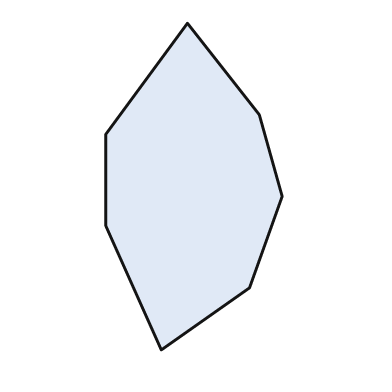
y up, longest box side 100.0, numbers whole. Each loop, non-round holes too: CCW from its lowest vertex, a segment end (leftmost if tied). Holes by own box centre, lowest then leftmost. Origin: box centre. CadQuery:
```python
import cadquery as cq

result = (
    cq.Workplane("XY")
    .moveTo(-10.0, -50.0)
    .lineTo(17.0, -31.0)
    .lineTo(27.0, -3.0)
    .lineTo(20.0, 22.0)
    .lineTo(-2.0, 50.0)
    .lineTo(-27.0, 16.0)
    .lineTo(-27.0, -12.0)
    .close()
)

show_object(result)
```